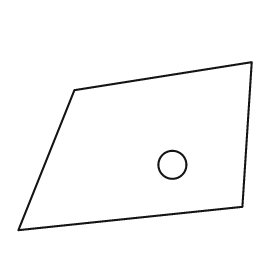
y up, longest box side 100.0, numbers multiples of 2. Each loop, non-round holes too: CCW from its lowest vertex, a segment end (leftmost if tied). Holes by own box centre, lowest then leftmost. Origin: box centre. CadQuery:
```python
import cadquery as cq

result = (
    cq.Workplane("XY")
    .moveTo(-50.0, -36.0)
    .lineTo(46.0, -26.0)
    .lineTo(50.0, 36.0)
    .lineTo(-26.0, 24.0)
    .close()
    .moveTo(16.0, -8.0)
    .circle(6.0)
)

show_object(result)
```